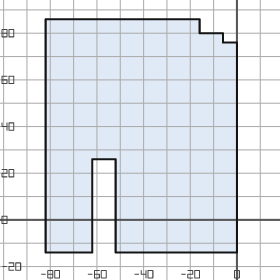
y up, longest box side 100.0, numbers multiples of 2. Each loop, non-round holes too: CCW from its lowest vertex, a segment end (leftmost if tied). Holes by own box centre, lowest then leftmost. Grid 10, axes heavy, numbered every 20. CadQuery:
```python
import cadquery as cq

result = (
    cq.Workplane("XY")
    .moveTo(-82.0, -14.0)
    .lineTo(-62.0, -14.0)
    .lineTo(-62.0, 26.0)
    .lineTo(-52.0, 26.0)
    .lineTo(-52.0, -14.0)
    .lineTo(0.0, -14.0)
    .lineTo(0.0, 76.0)
    .lineTo(-6.0, 76.0)
    .lineTo(-6.0, 80.0)
    .lineTo(-16.0, 80.0)
    .lineTo(-16.0, 86.0)
    .lineTo(-82.0, 86.0)
    .close()
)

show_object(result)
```